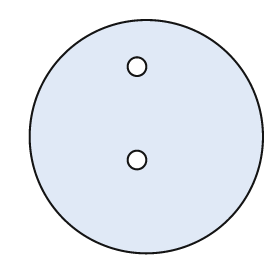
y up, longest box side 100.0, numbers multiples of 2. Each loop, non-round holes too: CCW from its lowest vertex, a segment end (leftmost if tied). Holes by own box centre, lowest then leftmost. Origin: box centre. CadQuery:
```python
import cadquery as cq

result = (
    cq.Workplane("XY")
    .moveTo(0.0, 0.0)
    .circle(50.0)
    .moveTo(-4.0, -10.0)
    .circle(4.0)
    .moveTo(-4.0, 30.0)
    .circle(4.0)
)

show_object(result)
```